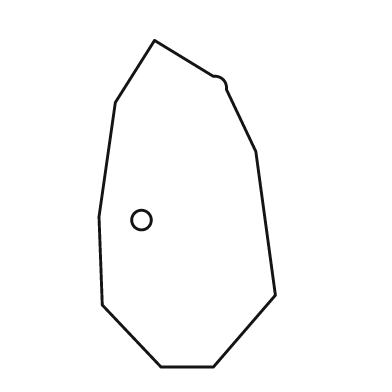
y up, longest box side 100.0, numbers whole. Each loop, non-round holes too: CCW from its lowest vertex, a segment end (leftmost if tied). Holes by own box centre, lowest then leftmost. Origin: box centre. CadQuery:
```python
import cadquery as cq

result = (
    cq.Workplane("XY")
    .moveTo(-8.0, -50.0)
    .lineTo(8.0, -50.0)
    .lineTo(27.0, -28.0)
    .lineTo(21.0, 16.0)
    .lineTo(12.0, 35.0)
    .threePointArc((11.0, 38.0), (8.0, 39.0))
    .lineTo(-10.0, 50.0)
    .lineTo(-22.0, 31.0)
    .lineTo(-27.0, -4.0)
    .lineTo(-26.0, -31.0)
    .close()
    .moveTo(-14.0, -5.0)
    .circle(3.0)
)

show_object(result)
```